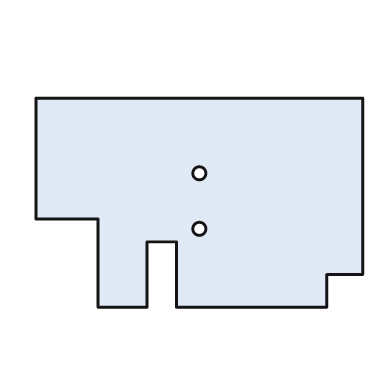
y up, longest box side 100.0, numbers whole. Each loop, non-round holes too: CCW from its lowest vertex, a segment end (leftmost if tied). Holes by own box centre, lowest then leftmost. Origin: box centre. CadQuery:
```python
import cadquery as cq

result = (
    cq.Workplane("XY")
    .moveTo(-31.0, -32.0)
    .lineTo(-16.0, -32.0)
    .lineTo(-16.0, -12.0)
    .lineTo(-7.0, -12.0)
    .lineTo(-7.0, -32.0)
    .lineTo(39.0, -32.0)
    .lineTo(39.0, -22.0)
    .lineTo(50.0, -22.0)
    .lineTo(50.0, 32.0)
    .lineTo(-50.0, 32.0)
    .lineTo(-50.0, -5.0)
    .lineTo(-31.0, -5.0)
    .close()
    .moveTo(0.0, -8.0)
    .circle(2.0)
    .moveTo(0.0, 9.0)
    .circle(2.0)
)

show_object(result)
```